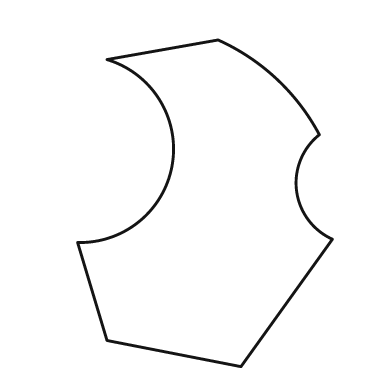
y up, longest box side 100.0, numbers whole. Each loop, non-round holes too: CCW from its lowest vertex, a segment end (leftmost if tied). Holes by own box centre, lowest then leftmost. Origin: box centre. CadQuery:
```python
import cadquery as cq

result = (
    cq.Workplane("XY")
    .moveTo(11.0, -50.0)
    .lineTo(39.0, -11.0)
    .threePointArc((28.0, 4.0), (35.0, 21.0))
    .threePointArc((22.0, 38.0), (4.0, 50.0))
    .lineTo(-30.0, 44.0)
    .threePointArc((-10.0, 12.0), (-39.0, -12.0))
    .lineTo(-30.0, -42.0)
    .close()
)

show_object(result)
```